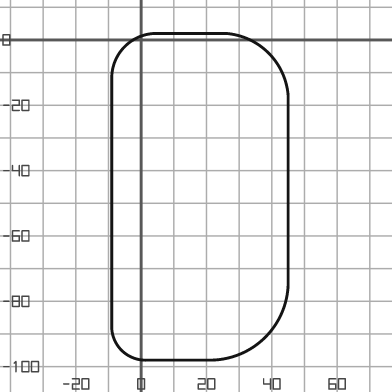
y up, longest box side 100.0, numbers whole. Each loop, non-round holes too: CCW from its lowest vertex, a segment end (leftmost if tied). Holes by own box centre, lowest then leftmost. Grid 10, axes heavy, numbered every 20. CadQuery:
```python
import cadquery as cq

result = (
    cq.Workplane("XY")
    .moveTo(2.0, -98.0)
    .lineTo(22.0, -98.0)
    .threePointArc((38.0, -91.0), (45.0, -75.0))
    .lineTo(45.0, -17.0)
    .threePointArc((39.0, -4.0), (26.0, 2.0))
    .lineTo(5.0, 2.0)
    .threePointArc((-5.0, -2.0), (-9.0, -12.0))
    .lineTo(-9.0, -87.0)
    .threePointArc((-6.0, -95.0), (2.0, -98.0))
    .close()
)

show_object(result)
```